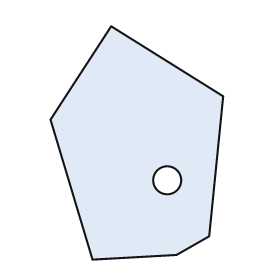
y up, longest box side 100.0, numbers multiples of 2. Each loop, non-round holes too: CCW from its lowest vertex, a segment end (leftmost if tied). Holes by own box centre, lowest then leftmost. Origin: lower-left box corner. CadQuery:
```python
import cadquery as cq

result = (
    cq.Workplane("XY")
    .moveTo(18.0, 0.0)
    .lineTo(54.0, 2.0)
    .lineTo(68.0, 10.0)
    .lineTo(74.0, 70.0)
    .lineTo(26.0, 100.0)
    .lineTo(0.0, 60.0)
    .close()
    .moveTo(50.0, 34.0)
    .circle(6.0)
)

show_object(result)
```